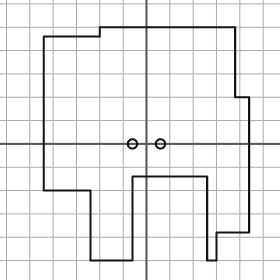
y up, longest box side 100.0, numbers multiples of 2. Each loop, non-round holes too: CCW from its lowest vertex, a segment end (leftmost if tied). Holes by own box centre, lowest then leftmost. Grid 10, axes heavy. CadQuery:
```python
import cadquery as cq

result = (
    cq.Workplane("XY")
    .moveTo(-24.0, -50.0)
    .lineTo(-6.0, -50.0)
    .lineTo(-6.0, -14.0)
    .lineTo(26.0, -14.0)
    .lineTo(26.0, -50.0)
    .lineTo(30.0, -50.0)
    .lineTo(30.0, -38.0)
    .lineTo(44.0, -38.0)
    .lineTo(44.0, 20.0)
    .lineTo(38.0, 20.0)
    .lineTo(38.0, 50.0)
    .lineTo(-20.0, 50.0)
    .lineTo(-20.0, 46.0)
    .lineTo(-44.0, 46.0)
    .lineTo(-44.0, -20.0)
    .lineTo(-24.0, -20.0)
    .close()
    .moveTo(-6.0, 0.0)
    .circle(2.0)
    .moveTo(6.0, 0.0)
    .circle(2.0)
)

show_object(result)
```